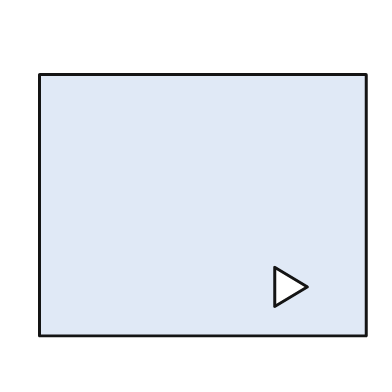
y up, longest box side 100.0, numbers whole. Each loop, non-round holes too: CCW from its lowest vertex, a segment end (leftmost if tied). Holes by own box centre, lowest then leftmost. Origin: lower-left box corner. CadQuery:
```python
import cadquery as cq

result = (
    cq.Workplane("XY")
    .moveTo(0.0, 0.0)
    .lineTo(100.0, 0.0)
    .lineTo(100.0, 80.0)
    .lineTo(0.0, 80.0)
    .close()
    .moveTo(72.0, 9.0)
    .lineTo(82.0, 15.0)
    .lineTo(72.0, 21.0)
    .close()
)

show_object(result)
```